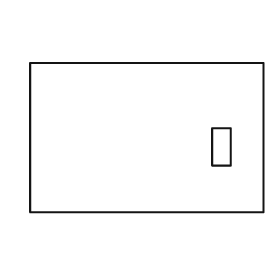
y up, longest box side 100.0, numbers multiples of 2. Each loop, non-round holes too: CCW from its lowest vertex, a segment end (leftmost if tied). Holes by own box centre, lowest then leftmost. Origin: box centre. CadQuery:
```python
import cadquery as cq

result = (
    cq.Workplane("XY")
    .moveTo(-50.0, -32.0)
    .lineTo(50.0, -32.0)
    .lineTo(50.0, 32.0)
    .lineTo(-50.0, 32.0)
    .close()
    .moveTo(28.0, -12.0)
    .lineTo(36.0, -12.0)
    .lineTo(36.0, 4.0)
    .lineTo(28.0, 4.0)
    .close()
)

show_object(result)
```